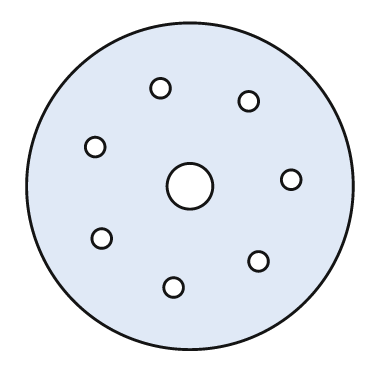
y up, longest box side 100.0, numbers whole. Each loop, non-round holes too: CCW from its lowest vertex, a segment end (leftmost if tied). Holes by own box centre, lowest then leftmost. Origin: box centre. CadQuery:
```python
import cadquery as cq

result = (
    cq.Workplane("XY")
    .moveTo(0.0, 0.0)
    .circle(50.0)
    .moveTo(-5.0, -31.0)
    .circle(3.0)
    .moveTo(21.0, -23.0)
    .circle(3.0)
    .moveTo(-27.0, -16.0)
    .circle(3.0)
    .moveTo(0.0, 0.0)
    .circle(7.0)
    .moveTo(31.0, 2.0)
    .circle(3.0)
    .moveTo(-29.0, 12.0)
    .circle(3.0)
    .moveTo(18.0, 26.0)
    .circle(3.0)
    .moveTo(-9.0, 30.0)
    .circle(3.0)
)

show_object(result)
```